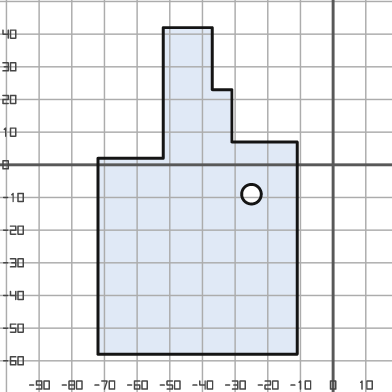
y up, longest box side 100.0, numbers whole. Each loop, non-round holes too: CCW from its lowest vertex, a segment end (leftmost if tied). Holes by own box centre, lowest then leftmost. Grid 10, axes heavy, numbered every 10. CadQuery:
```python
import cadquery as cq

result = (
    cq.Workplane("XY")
    .moveTo(-72.0, -58.0)
    .lineTo(-11.0, -58.0)
    .lineTo(-11.0, 7.0)
    .lineTo(-31.0, 7.0)
    .lineTo(-31.0, 23.0)
    .lineTo(-37.0, 23.0)
    .lineTo(-37.0, 42.0)
    .lineTo(-52.0, 42.0)
    .lineTo(-52.0, 2.0)
    .lineTo(-72.0, 2.0)
    .close()
    .moveTo(-25.0, -9.0)
    .circle(3.0)
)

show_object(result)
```